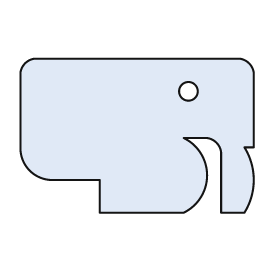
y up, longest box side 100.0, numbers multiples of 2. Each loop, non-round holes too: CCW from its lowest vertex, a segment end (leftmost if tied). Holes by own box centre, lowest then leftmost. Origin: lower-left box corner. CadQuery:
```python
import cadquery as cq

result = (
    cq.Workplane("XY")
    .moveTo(34.0, 0.0)
    .lineTo(70.0, 0.0)
    .threePointArc((80.0, 16.0), (70.0, 32.0))
    .lineTo(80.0, 32.0)
    .threePointArc((84.0, 30.0), (86.0, 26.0))
    .lineTo(86.0, 0.0)
    .lineTo(96.0, 0.0)
    .threePointArc((100.0, 14.0), (96.0, 28.0))
    .lineTo(100.0, 28.0)
    .lineTo(100.0, 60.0)
    .threePointArc((98.0, 64.0), (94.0, 66.0))
    .lineTo(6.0, 66.0)
    .threePointArc((2.0, 64.0), (0.0, 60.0))
    .lineTo(0.0, 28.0)
    .threePointArc((4.0, 18.0), (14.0, 14.0))
    .lineTo(34.0, 14.0)
    .close()
    .moveTo(72.0, 52.0)
    .circle(4.0)
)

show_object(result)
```